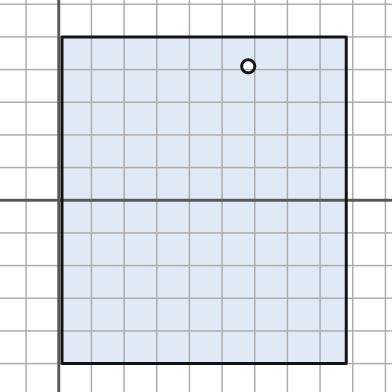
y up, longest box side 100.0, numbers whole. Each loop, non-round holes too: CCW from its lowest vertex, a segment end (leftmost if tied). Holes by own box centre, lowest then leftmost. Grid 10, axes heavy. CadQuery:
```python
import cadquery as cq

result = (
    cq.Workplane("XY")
    .moveTo(1.0, -50.0)
    .lineTo(88.0, -50.0)
    .lineTo(88.0, 50.0)
    .lineTo(1.0, 50.0)
    .close()
    .moveTo(58.0, 41.0)
    .circle(2.0)
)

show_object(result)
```